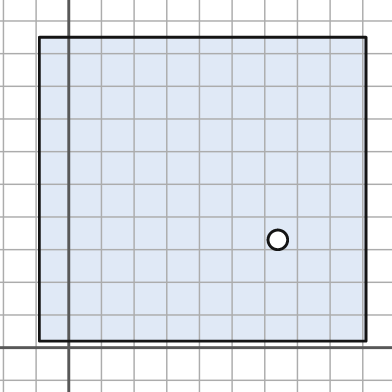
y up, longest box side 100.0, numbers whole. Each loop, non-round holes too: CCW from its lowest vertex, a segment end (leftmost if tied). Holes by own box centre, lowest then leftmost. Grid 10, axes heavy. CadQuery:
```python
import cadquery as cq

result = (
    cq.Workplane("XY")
    .moveTo(-9.0, 2.0)
    .lineTo(91.0, 2.0)
    .lineTo(91.0, 95.0)
    .lineTo(-9.0, 95.0)
    .close()
    .moveTo(64.0, 33.0)
    .circle(3.0)
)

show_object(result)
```